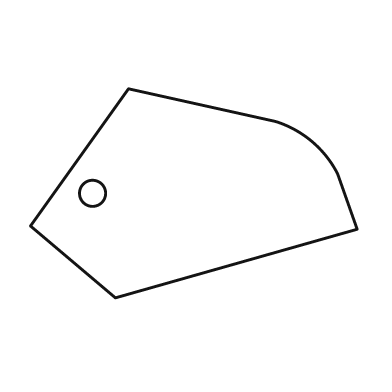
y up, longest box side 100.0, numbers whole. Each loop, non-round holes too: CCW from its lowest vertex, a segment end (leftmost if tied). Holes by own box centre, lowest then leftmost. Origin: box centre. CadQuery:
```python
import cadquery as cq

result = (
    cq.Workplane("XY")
    .moveTo(-24.0, -32.0)
    .lineTo(50.0, -11.0)
    .lineTo(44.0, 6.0)
    .threePointArc((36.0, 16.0), (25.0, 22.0))
    .lineTo(-20.0, 32.0)
    .lineTo(-50.0, -10.0)
    .close()
    .moveTo(-31.0, 0.0)
    .circle(4.0)
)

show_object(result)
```